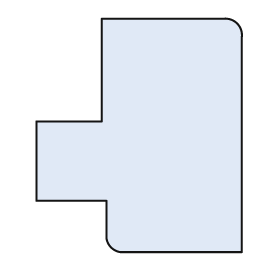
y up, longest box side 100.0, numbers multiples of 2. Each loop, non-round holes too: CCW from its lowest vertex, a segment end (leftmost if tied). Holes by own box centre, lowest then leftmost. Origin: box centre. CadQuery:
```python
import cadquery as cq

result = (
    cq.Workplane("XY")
    .moveTo(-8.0, -50.0)
    .lineTo(44.0, -50.0)
    .lineTo(44.0, 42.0)
    .threePointArc((42.0, 48.0), (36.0, 50.0))
    .lineTo(-16.0, 50.0)
    .lineTo(-16.0, 6.0)
    .lineTo(-44.0, 6.0)
    .lineTo(-44.0, -28.0)
    .lineTo(-14.0, -28.0)
    .lineTo(-14.0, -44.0)
    .threePointArc((-12.0, -48.0), (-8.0, -50.0))
    .close()
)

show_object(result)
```